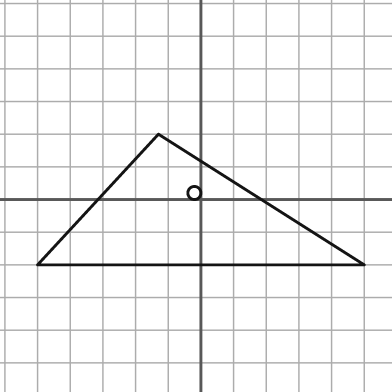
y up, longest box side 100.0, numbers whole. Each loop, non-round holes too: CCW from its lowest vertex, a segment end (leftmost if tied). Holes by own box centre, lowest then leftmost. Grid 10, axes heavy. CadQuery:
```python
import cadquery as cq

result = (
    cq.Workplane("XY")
    .moveTo(-50.0, -20.0)
    .lineTo(50.0, -20.0)
    .lineTo(-13.0, 20.0)
    .close()
    .moveTo(-2.0, 2.0)
    .circle(2.0)
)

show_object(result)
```